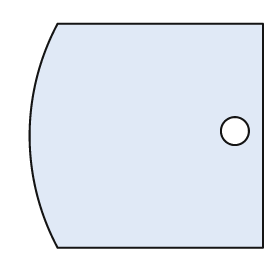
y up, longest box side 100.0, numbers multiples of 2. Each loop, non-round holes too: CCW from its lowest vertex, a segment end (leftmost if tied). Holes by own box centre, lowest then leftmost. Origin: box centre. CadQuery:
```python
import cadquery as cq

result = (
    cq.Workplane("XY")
    .moveTo(-38.0, -48.0)
    .lineTo(50.0, -48.0)
    .lineTo(50.0, 48.0)
    .lineTo(-38.0, 48.0)
    .threePointArc((-50.0, 0.0), (-38.0, -48.0))
    .close()
    .moveTo(38.0, 2.0)
    .circle(6.0)
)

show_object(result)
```